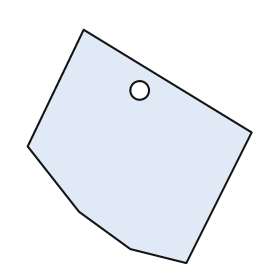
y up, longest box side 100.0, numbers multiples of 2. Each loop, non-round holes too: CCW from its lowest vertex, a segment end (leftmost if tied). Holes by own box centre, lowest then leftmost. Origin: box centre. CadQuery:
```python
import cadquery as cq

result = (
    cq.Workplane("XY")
    .moveTo(20.0, -50.0)
    .lineTo(48.0, 6.0)
    .lineTo(-24.0, 50.0)
    .lineTo(-48.0, 0.0)
    .lineTo(-26.0, -28.0)
    .lineTo(-4.0, -44.0)
    .close()
    .moveTo(0.0, 24.0)
    .circle(4.0)
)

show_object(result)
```